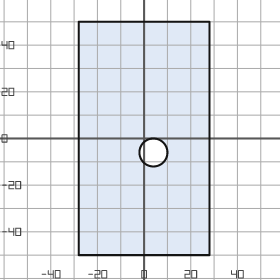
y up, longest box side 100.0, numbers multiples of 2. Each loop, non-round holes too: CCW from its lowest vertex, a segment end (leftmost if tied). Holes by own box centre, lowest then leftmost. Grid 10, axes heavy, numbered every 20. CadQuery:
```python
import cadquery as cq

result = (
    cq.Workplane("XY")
    .moveTo(-28.0, -50.0)
    .lineTo(28.0, -50.0)
    .lineTo(28.0, 50.0)
    .lineTo(-28.0, 50.0)
    .close()
    .moveTo(4.0, -6.0)
    .circle(6.0)
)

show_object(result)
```